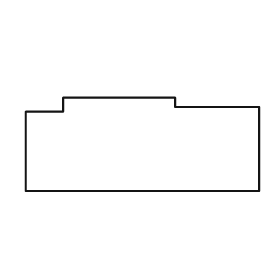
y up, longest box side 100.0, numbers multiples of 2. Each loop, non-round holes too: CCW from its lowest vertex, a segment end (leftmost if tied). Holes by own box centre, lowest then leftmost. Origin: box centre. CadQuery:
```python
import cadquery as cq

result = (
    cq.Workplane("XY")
    .moveTo(-50.0, -20.0)
    .lineTo(50.0, -20.0)
    .lineTo(50.0, 16.0)
    .lineTo(14.0, 16.0)
    .lineTo(14.0, 20.0)
    .lineTo(-34.0, 20.0)
    .lineTo(-34.0, 14.0)
    .lineTo(-50.0, 14.0)
    .close()
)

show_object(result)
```